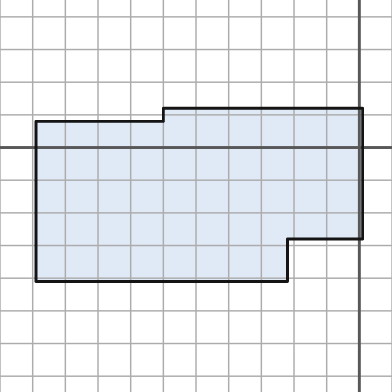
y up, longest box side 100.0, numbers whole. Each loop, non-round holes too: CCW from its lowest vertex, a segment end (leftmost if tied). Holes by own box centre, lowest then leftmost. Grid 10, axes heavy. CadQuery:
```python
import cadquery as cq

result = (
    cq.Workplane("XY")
    .moveTo(-99.0, -41.0)
    .lineTo(-22.0, -41.0)
    .lineTo(-22.0, -28.0)
    .lineTo(1.0, -28.0)
    .lineTo(1.0, 12.0)
    .lineTo(-60.0, 12.0)
    .lineTo(-60.0, 8.0)
    .lineTo(-99.0, 8.0)
    .close()
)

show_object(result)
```